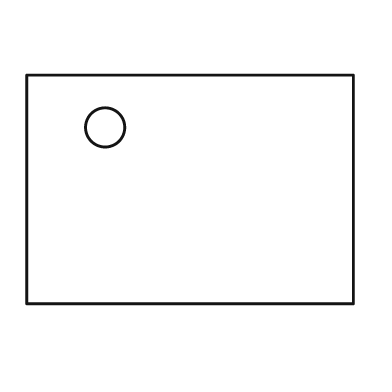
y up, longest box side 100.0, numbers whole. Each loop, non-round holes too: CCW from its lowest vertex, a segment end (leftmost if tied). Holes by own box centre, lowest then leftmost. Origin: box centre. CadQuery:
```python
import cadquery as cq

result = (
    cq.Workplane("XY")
    .moveTo(-50.0, -35.0)
    .lineTo(50.0, -35.0)
    .lineTo(50.0, 35.0)
    .lineTo(-50.0, 35.0)
    .close()
    .moveTo(-26.0, 19.0)
    .circle(6.0)
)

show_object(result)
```